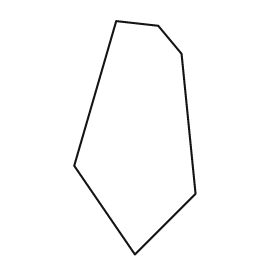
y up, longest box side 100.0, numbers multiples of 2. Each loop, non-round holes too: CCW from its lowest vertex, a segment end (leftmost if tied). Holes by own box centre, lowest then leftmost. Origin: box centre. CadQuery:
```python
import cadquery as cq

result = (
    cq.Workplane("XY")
    .moveTo(0.0, -50.0)
    .lineTo(26.0, -24.0)
    .lineTo(20.0, 36.0)
    .lineTo(10.0, 48.0)
    .lineTo(-8.0, 50.0)
    .lineTo(-26.0, -12.0)
    .close()
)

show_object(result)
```